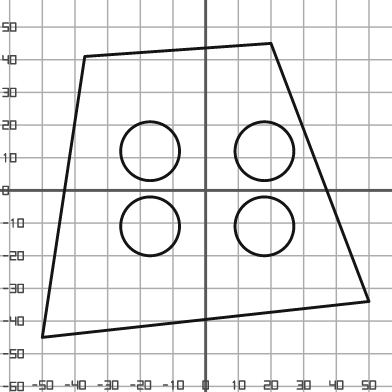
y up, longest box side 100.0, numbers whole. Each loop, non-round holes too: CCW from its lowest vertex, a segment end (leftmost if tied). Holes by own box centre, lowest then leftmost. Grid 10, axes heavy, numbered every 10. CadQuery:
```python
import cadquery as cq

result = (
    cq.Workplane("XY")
    .moveTo(-50.0, -45.0)
    .lineTo(50.0, -34.0)
    .lineTo(20.0, 45.0)
    .lineTo(-37.0, 41.0)
    .close()
    .moveTo(-17.0, -11.0)
    .circle(9.0)
    .moveTo(18.0, -11.0)
    .circle(9.0)
    .moveTo(-17.0, 12.0)
    .circle(9.0)
    .moveTo(18.0, 12.0)
    .circle(9.0)
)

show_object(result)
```